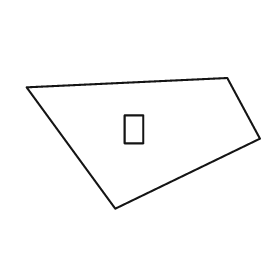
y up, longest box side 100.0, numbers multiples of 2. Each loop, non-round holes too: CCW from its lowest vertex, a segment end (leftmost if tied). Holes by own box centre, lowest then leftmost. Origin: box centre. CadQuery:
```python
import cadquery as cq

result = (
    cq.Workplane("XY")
    .moveTo(-12.0, -28.0)
    .lineTo(50.0, 2.0)
    .lineTo(36.0, 28.0)
    .lineTo(-50.0, 24.0)
    .close()
    .moveTo(-8.0, 0.0)
    .lineTo(0.0, 0.0)
    .lineTo(0.0, 12.0)
    .lineTo(-8.0, 12.0)
    .close()
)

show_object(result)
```